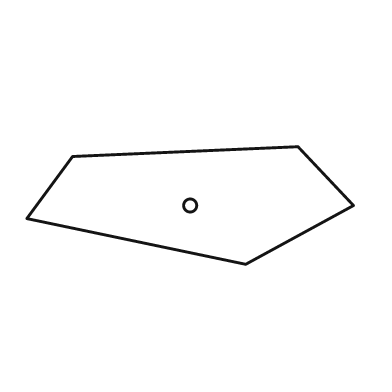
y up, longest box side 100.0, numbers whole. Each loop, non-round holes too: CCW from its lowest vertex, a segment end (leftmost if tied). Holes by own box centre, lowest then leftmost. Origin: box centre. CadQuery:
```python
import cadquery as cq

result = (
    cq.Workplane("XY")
    .moveTo(17.0, -18.0)
    .lineTo(50.0, 0.0)
    .lineTo(33.0, 18.0)
    .lineTo(-36.0, 15.0)
    .lineTo(-50.0, -4.0)
    .close()
    .moveTo(0.0, 0.0)
    .circle(2.0)
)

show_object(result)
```